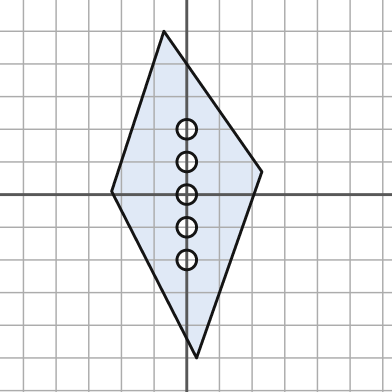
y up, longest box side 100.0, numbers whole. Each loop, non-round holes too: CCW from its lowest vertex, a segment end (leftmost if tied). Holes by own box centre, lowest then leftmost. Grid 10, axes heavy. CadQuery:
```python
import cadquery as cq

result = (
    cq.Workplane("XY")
    .moveTo(3.0, -50.0)
    .lineTo(23.0, 7.0)
    .lineTo(-7.0, 50.0)
    .lineTo(-23.0, 1.0)
    .close()
    .moveTo(0.0, -20.0)
    .circle(3.0)
    .moveTo(0.0, -10.0)
    .circle(3.0)
    .moveTo(0.0, 0.0)
    .circle(3.0)
    .moveTo(0.0, 10.0)
    .circle(3.0)
    .moveTo(0.0, 20.0)
    .circle(3.0)
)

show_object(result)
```